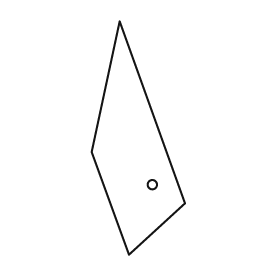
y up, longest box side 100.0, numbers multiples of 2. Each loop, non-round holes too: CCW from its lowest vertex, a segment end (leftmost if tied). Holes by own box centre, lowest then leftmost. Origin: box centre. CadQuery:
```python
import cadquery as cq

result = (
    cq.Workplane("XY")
    .moveTo(-4.0, -50.0)
    .lineTo(20.0, -28.0)
    .lineTo(-8.0, 50.0)
    .lineTo(-20.0, -6.0)
    .close()
    .moveTo(6.0, -20.0)
    .circle(2.0)
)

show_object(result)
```